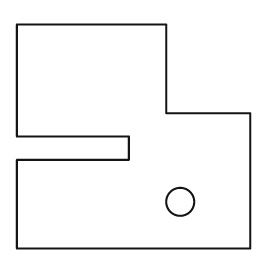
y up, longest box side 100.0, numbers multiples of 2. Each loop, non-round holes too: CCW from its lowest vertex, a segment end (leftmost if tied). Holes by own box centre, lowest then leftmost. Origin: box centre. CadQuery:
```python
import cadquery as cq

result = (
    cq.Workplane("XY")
    .moveTo(-50.0, -48.0)
    .lineTo(50.0, -48.0)
    .lineTo(50.0, 10.0)
    .lineTo(14.0, 10.0)
    .lineTo(14.0, 48.0)
    .lineTo(-50.0, 48.0)
    .lineTo(-50.0, 0.0)
    .lineTo(-2.0, 0.0)
    .lineTo(-2.0, -10.0)
    .lineTo(-50.0, -10.0)
    .close()
    .moveTo(20.0, -28.0)
    .circle(6.0)
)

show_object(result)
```